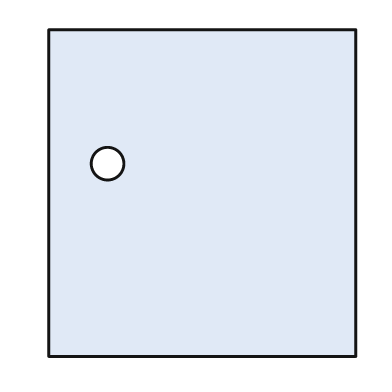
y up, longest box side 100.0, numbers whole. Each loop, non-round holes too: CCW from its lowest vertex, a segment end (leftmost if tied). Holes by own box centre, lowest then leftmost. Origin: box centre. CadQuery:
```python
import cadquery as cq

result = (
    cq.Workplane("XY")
    .moveTo(-47.0, -50.0)
    .lineTo(47.0, -50.0)
    .lineTo(47.0, 50.0)
    .lineTo(-47.0, 50.0)
    .close()
    .moveTo(-29.0, 9.0)
    .circle(5.0)
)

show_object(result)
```